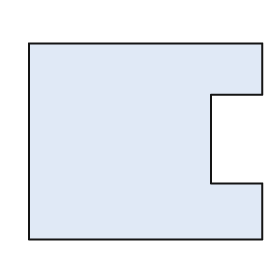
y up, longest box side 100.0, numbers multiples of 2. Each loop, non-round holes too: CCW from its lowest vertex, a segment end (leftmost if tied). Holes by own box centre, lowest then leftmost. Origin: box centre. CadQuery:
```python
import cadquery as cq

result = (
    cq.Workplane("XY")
    .moveTo(-50.0, -42.0)
    .lineTo(50.0, -42.0)
    .lineTo(50.0, -18.0)
    .lineTo(28.0, -18.0)
    .lineTo(28.0, 20.0)
    .lineTo(50.0, 20.0)
    .lineTo(50.0, 42.0)
    .lineTo(-50.0, 42.0)
    .close()
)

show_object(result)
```